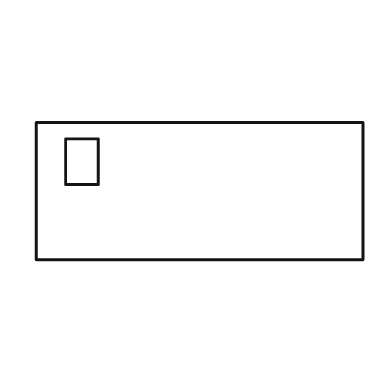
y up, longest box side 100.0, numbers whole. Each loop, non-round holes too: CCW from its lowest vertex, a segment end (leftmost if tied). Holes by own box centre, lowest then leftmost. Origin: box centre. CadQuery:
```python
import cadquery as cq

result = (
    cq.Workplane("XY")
    .moveTo(-50.0, -21.0)
    .lineTo(50.0, -21.0)
    .lineTo(50.0, 21.0)
    .lineTo(-50.0, 21.0)
    .close()
    .moveTo(-41.0, 2.0)
    .lineTo(-31.0, 2.0)
    .lineTo(-31.0, 16.0)
    .lineTo(-41.0, 16.0)
    .close()
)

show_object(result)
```